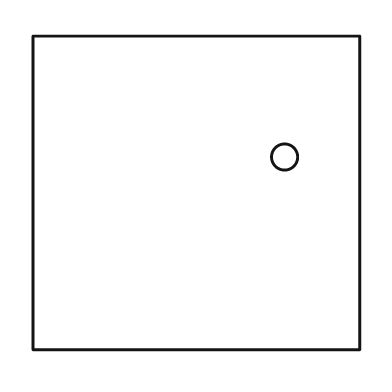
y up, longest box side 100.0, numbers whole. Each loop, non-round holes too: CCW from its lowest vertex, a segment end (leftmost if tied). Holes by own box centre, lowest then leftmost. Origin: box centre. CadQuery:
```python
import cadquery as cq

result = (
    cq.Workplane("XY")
    .moveTo(-50.0, -48.0)
    .lineTo(50.0, -48.0)
    .lineTo(50.0, 48.0)
    .lineTo(-50.0, 48.0)
    .close()
    .moveTo(27.0, 11.0)
    .circle(4.0)
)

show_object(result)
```